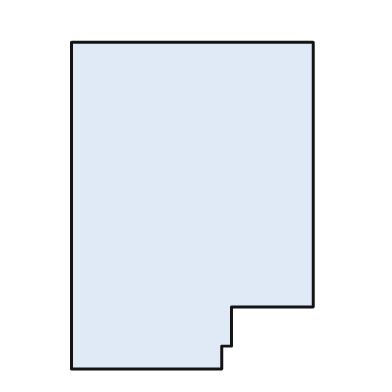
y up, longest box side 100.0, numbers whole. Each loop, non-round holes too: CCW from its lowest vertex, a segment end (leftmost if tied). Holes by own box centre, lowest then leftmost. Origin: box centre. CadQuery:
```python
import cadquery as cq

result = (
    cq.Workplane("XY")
    .moveTo(-37.0, -50.0)
    .lineTo(9.0, -50.0)
    .lineTo(9.0, -43.0)
    .lineTo(12.0, -43.0)
    .lineTo(12.0, -31.0)
    .lineTo(37.0, -31.0)
    .lineTo(37.0, 50.0)
    .lineTo(-37.0, 50.0)
    .close()
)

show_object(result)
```